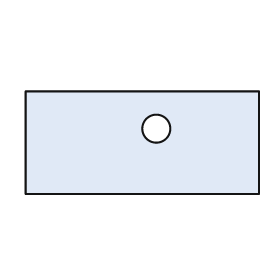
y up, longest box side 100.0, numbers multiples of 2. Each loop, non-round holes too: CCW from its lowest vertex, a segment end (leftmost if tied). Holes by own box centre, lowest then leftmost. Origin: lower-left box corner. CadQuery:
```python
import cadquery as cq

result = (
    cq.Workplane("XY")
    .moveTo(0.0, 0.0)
    .lineTo(100.0, 0.0)
    .lineTo(100.0, 44.0)
    .lineTo(0.0, 44.0)
    .close()
    .moveTo(56.0, 28.0)
    .circle(6.0)
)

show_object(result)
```